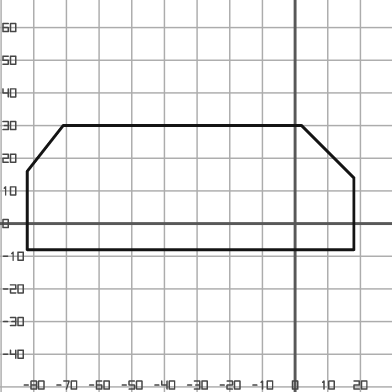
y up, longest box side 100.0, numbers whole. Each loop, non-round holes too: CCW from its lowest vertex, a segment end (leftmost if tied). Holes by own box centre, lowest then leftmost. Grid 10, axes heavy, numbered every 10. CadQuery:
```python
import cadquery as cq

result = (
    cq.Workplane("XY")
    .moveTo(-82.0, -8.0)
    .lineTo(18.0, -8.0)
    .lineTo(18.0, 14.0)
    .lineTo(2.0, 30.0)
    .lineTo(-71.0, 30.0)
    .lineTo(-82.0, 16.0)
    .close()
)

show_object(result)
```